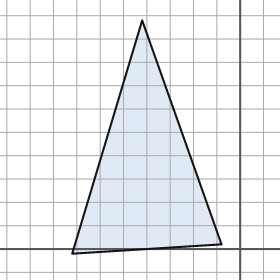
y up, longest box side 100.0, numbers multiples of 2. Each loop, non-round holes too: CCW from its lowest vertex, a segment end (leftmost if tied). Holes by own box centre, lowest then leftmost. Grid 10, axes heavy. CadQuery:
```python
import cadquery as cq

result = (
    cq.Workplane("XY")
    .moveTo(-72.0, -2.0)
    .lineTo(-8.0, 2.0)
    .lineTo(-42.0, 98.0)
    .close()
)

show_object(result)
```